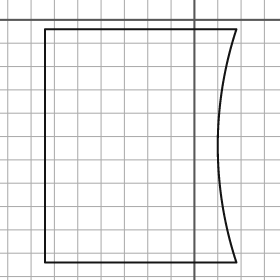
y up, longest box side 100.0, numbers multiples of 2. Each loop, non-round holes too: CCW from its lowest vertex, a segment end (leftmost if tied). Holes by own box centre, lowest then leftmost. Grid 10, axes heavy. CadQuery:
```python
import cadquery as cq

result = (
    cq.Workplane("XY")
    .moveTo(-64.0, -104.0)
    .lineTo(18.0, -104.0)
    .threePointArc((10.0, -54.0), (18.0, -4.0))
    .lineTo(-64.0, -4.0)
    .close()
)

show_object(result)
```